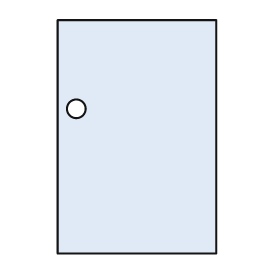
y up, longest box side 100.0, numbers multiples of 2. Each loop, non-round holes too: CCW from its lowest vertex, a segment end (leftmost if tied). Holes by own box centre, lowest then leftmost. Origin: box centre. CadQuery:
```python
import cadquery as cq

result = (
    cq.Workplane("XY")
    .moveTo(-34.0, -50.0)
    .lineTo(34.0, -50.0)
    .lineTo(34.0, 50.0)
    .lineTo(-34.0, 50.0)
    .close()
    .moveTo(-26.0, 12.0)
    .circle(4.0)
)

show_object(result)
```